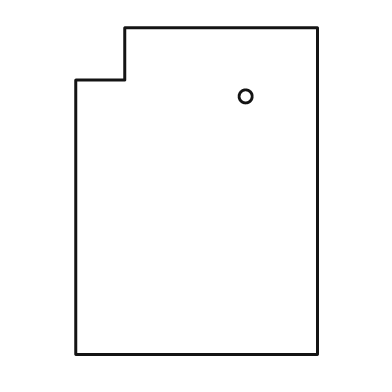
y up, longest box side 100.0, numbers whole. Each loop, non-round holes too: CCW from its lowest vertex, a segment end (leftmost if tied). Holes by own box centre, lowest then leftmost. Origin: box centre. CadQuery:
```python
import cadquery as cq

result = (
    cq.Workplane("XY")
    .moveTo(-37.0, -50.0)
    .lineTo(37.0, -50.0)
    .lineTo(37.0, 50.0)
    .lineTo(-22.0, 50.0)
    .lineTo(-22.0, 34.0)
    .lineTo(-37.0, 34.0)
    .close()
    .moveTo(15.0, 29.0)
    .circle(2.0)
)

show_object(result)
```